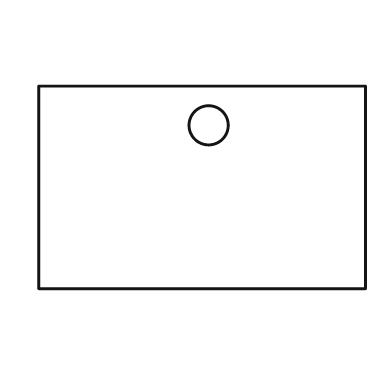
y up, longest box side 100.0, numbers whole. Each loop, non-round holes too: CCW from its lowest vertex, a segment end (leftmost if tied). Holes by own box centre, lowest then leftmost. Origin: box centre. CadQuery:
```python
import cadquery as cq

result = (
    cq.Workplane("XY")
    .moveTo(-50.0, -31.0)
    .lineTo(50.0, -31.0)
    .lineTo(50.0, 31.0)
    .lineTo(-50.0, 31.0)
    .close()
    .moveTo(2.0, 19.0)
    .circle(6.0)
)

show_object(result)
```